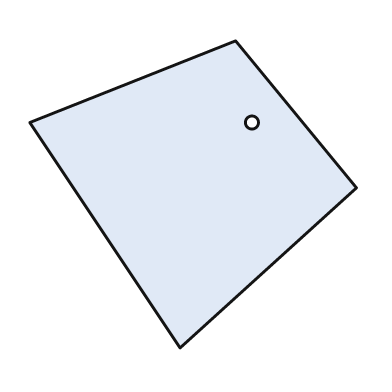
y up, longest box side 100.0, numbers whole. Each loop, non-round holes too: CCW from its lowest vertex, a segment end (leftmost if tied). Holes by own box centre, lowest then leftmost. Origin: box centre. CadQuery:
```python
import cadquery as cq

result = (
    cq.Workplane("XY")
    .moveTo(-4.0, -47.0)
    .lineTo(50.0, 2.0)
    .lineTo(13.0, 47.0)
    .lineTo(-50.0, 22.0)
    .close()
    .moveTo(18.0, 22.0)
    .circle(2.0)
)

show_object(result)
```